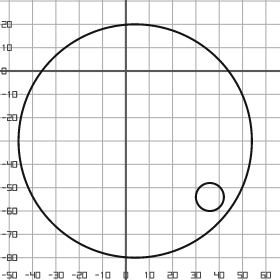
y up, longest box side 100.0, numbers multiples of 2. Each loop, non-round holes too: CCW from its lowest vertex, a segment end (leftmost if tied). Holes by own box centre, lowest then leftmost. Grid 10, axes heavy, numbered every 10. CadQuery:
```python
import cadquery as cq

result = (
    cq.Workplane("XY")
    .moveTo(4.0, -30.0)
    .circle(50.0)
    .moveTo(36.0, -54.0)
    .circle(6.0)
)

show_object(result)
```